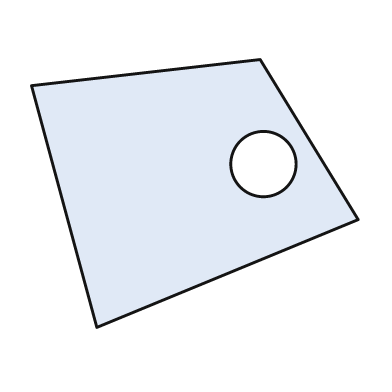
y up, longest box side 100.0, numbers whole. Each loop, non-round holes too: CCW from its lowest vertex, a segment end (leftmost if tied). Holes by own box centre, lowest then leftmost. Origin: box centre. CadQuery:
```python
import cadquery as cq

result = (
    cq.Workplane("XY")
    .moveTo(-30.0, -41.0)
    .lineTo(50.0, -8.0)
    .lineTo(20.0, 41.0)
    .lineTo(-50.0, 33.0)
    .close()
    .moveTo(21.0, 9.0)
    .circle(10.0)
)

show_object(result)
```